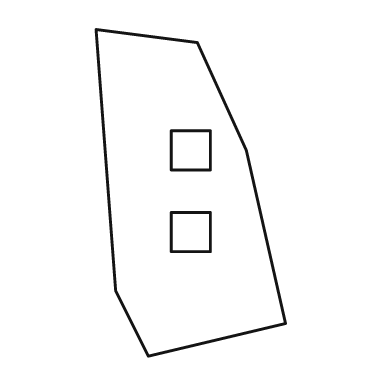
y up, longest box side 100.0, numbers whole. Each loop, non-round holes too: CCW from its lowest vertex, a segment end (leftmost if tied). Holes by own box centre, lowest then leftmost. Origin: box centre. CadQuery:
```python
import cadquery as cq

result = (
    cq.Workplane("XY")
    .moveTo(-13.0, -50.0)
    .lineTo(29.0, -40.0)
    .lineTo(17.0, 13.0)
    .lineTo(2.0, 46.0)
    .lineTo(-29.0, 50.0)
    .lineTo(-23.0, -30.0)
    .close()
    .moveTo(-6.0, -18.0)
    .lineTo(6.0, -18.0)
    .lineTo(6.0, -6.0)
    .lineTo(-6.0, -6.0)
    .close()
    .moveTo(-6.0, 7.0)
    .lineTo(6.0, 7.0)
    .lineTo(6.0, 19.0)
    .lineTo(-6.0, 19.0)
    .close()
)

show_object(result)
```